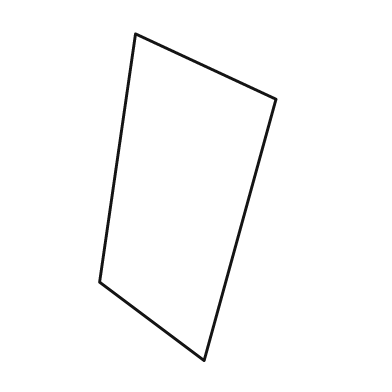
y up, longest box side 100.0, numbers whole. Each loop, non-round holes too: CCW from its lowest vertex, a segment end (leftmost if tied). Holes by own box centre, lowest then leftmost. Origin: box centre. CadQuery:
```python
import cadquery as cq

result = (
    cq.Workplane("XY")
    .moveTo(5.0, -50.0)
    .lineTo(27.0, 30.0)
    .lineTo(-16.0, 50.0)
    .lineTo(-27.0, -26.0)
    .close()
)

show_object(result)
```